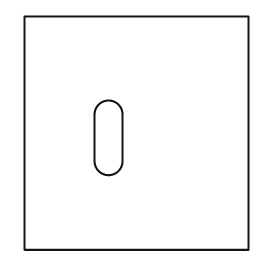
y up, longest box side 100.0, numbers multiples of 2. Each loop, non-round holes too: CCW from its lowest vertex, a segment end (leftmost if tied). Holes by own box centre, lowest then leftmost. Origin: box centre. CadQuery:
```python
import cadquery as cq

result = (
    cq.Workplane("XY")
    .moveTo(-48.0, -50.0)
    .lineTo(48.0, -50.0)
    .lineTo(48.0, 50.0)
    .lineTo(-48.0, 50.0)
    .close()
    .moveTo(-18.0, -12.0)
    .threePointArc((-12.0, -18.0), (-6.0, -12.0))
    .lineTo(-6.0, 8.0)
    .threePointArc((-12.0, 14.0), (-18.0, 8.0))
    .close()
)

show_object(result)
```